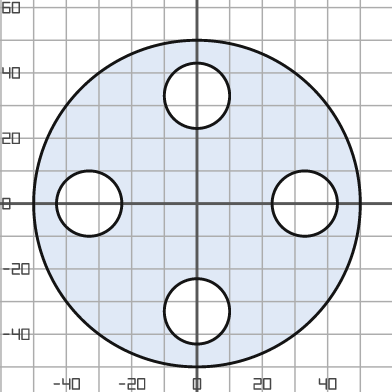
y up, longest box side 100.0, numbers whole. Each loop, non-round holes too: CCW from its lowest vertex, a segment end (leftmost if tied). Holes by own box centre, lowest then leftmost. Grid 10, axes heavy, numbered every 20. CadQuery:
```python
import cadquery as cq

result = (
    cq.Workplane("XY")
    .moveTo(0.0, 0.0)
    .circle(50.0)
    .moveTo(0.0, -33.0)
    .circle(10.0)
    .moveTo(-33.0, 0.0)
    .circle(10.0)
    .moveTo(33.0, 0.0)
    .circle(10.0)
    .moveTo(0.0, 33.0)
    .circle(10.0)
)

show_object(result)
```